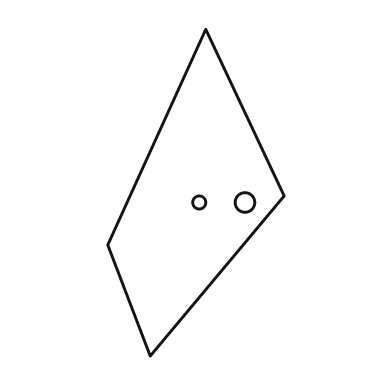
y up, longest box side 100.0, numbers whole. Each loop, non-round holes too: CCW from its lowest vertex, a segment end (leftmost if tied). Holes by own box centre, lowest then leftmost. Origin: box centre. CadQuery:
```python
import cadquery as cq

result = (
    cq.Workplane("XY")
    .moveTo(-14.0, -50.0)
    .lineTo(27.0, -1.0)
    .lineTo(3.0, 50.0)
    .lineTo(-27.0, -16.0)
    .close()
    .moveTo(1.0, -3.0)
    .circle(2.0)
    .moveTo(15.0, -3.0)
    .circle(3.0)
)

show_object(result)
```